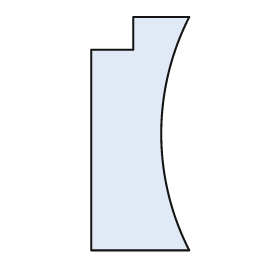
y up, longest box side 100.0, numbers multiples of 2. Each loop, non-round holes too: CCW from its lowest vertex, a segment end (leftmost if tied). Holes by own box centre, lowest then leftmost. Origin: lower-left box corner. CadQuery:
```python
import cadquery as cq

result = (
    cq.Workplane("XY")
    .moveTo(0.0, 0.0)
    .lineTo(42.0, 0.0)
    .threePointArc((30.0, 50.0), (42.0, 100.0))
    .lineTo(18.0, 100.0)
    .lineTo(18.0, 86.0)
    .lineTo(0.0, 86.0)
    .close()
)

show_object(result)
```